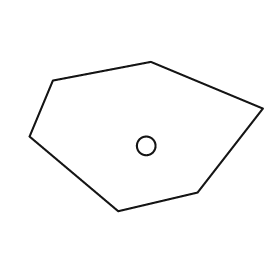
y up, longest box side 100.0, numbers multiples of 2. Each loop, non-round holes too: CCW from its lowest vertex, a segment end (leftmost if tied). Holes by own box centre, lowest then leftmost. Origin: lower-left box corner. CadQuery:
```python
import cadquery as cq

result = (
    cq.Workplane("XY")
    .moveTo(38.0, 0.0)
    .lineTo(72.0, 8.0)
    .lineTo(100.0, 44.0)
    .lineTo(52.0, 64.0)
    .lineTo(10.0, 56.0)
    .lineTo(0.0, 32.0)
    .close()
    .moveTo(50.0, 28.0)
    .circle(4.0)
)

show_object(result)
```